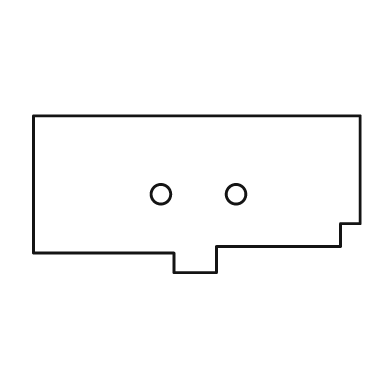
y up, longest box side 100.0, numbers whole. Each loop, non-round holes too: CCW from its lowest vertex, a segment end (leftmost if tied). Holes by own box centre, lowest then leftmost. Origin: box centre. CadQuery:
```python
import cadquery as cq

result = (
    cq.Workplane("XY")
    .moveTo(-7.0, -24.0)
    .lineTo(6.0, -24.0)
    .lineTo(6.0, -16.0)
    .lineTo(44.0, -16.0)
    .lineTo(44.0, -9.0)
    .lineTo(50.0, -9.0)
    .lineTo(50.0, 24.0)
    .lineTo(-50.0, 24.0)
    .lineTo(-50.0, -18.0)
    .lineTo(-7.0, -18.0)
    .close()
    .moveTo(-11.0, 0.0)
    .circle(3.0)
    .moveTo(12.0, 0.0)
    .circle(3.0)
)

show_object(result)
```